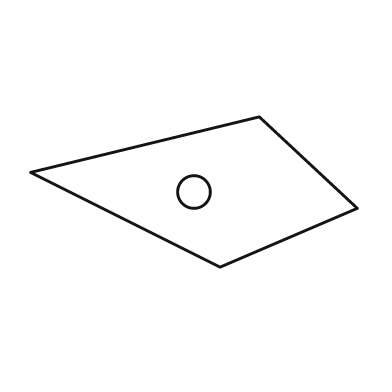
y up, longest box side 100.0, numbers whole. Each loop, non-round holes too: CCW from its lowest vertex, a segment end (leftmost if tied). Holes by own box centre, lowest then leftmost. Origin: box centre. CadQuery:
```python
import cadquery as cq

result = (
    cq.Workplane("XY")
    .moveTo(8.0, -23.0)
    .lineTo(50.0, -5.0)
    .lineTo(20.0, 23.0)
    .lineTo(-50.0, 6.0)
    .close()
    .moveTo(0.0, 0.0)
    .circle(5.0)
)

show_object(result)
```